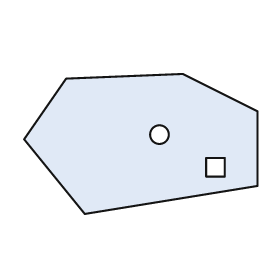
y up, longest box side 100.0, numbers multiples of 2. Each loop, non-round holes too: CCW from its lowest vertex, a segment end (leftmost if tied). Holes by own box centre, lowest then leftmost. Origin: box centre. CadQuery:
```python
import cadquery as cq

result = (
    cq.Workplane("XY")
    .moveTo(-24.0, -30.0)
    .lineTo(50.0, -18.0)
    .lineTo(50.0, 14.0)
    .lineTo(18.0, 30.0)
    .lineTo(-32.0, 28.0)
    .lineTo(-50.0, 2.0)
    .close()
    .moveTo(28.0, -14.0)
    .lineTo(36.0, -14.0)
    .lineTo(36.0, -6.0)
    .lineTo(28.0, -6.0)
    .close()
    .moveTo(8.0, 4.0)
    .circle(4.0)
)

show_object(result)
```